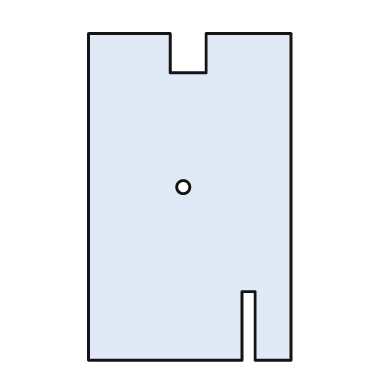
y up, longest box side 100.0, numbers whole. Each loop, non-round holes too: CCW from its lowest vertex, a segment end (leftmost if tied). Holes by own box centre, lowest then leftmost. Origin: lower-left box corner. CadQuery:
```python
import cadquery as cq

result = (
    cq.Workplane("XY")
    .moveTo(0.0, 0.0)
    .lineTo(47.0, 0.0)
    .lineTo(47.0, 21.0)
    .lineTo(51.0, 21.0)
    .lineTo(51.0, 0.0)
    .lineTo(62.0, 0.0)
    .lineTo(62.0, 100.0)
    .lineTo(36.0, 100.0)
    .lineTo(36.0, 88.0)
    .lineTo(25.0, 88.0)
    .lineTo(25.0, 100.0)
    .lineTo(0.0, 100.0)
    .close()
    .moveTo(29.0, 53.0)
    .circle(2.0)
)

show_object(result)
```